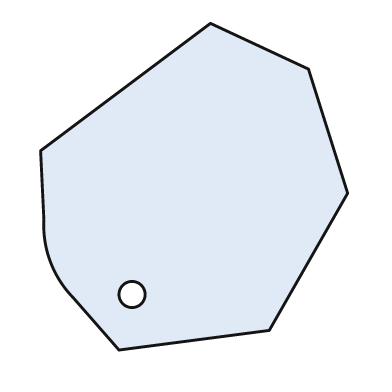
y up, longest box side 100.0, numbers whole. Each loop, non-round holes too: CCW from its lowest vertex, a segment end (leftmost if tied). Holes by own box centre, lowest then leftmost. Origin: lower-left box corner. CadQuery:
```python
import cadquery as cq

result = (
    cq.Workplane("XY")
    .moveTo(24.0, 0.0)
    .lineTo(70.0, 6.0)
    .lineTo(94.0, 48.0)
    .lineTo(82.0, 86.0)
    .lineTo(52.0, 100.0)
    .lineTo(0.0, 61.0)
    .lineTo(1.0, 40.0)
    .threePointArc((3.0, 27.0), (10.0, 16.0))
    .close()
    .moveTo(28.0, 17.0)
    .circle(4.0)
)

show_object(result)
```